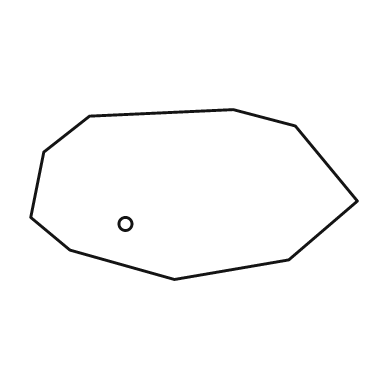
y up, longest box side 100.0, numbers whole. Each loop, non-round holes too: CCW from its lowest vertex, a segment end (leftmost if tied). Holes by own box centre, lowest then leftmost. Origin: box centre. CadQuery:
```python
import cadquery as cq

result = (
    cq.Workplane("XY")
    .moveTo(-6.0, -26.0)
    .lineTo(29.0, -20.0)
    .lineTo(50.0, -2.0)
    .lineTo(31.0, 21.0)
    .lineTo(12.0, 26.0)
    .lineTo(-32.0, 24.0)
    .lineTo(-46.0, 13.0)
    .lineTo(-50.0, -7.0)
    .lineTo(-38.0, -17.0)
    .close()
    .moveTo(-21.0, -9.0)
    .circle(2.0)
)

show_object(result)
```